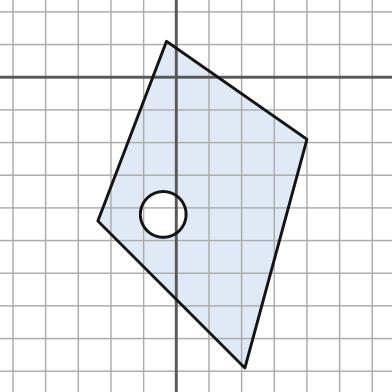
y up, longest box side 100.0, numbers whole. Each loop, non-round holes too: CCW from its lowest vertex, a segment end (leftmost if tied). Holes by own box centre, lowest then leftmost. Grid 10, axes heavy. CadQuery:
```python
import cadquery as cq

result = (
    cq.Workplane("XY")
    .moveTo(21.0, -89.0)
    .lineTo(40.0, -19.0)
    .lineTo(-3.0, 11.0)
    .lineTo(-24.0, -44.0)
    .close()
    .moveTo(-4.0, -42.0)
    .circle(7.0)
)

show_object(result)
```